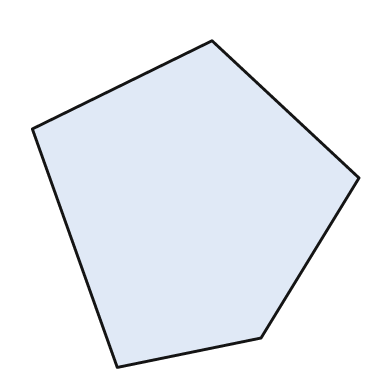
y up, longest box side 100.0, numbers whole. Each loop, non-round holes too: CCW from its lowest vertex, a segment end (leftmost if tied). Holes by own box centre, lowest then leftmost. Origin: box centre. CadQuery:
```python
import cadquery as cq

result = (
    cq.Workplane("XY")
    .moveTo(-24.0, -50.0)
    .lineTo(20.0, -41.0)
    .lineTo(50.0, 8.0)
    .lineTo(5.0, 50.0)
    .lineTo(-50.0, 23.0)
    .close()
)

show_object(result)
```